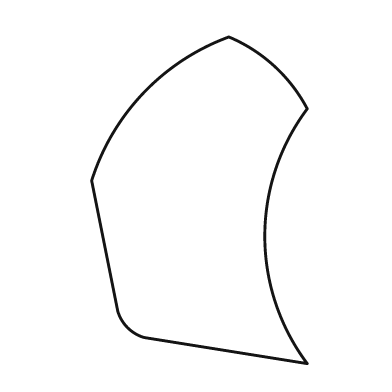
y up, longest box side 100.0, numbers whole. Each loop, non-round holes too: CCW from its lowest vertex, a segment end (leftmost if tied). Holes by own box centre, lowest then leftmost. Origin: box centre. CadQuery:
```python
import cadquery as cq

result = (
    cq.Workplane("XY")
    .moveTo(33.0, -50.0)
    .threePointArc((20.0, -11.0), (33.0, 28.0))
    .threePointArc((23.0, 41.0), (9.0, 50.0))
    .threePointArc((-17.0, 33.0), (-33.0, 6.0))
    .lineTo(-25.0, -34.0)
    .threePointArc((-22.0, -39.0), (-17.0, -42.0))
    .close()
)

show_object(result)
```